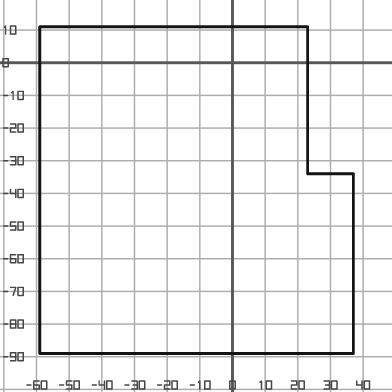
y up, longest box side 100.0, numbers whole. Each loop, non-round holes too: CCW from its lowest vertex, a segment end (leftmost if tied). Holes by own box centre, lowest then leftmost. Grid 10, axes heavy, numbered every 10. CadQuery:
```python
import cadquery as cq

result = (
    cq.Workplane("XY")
    .moveTo(-59.0, -89.0)
    .lineTo(37.0, -89.0)
    .lineTo(37.0, -34.0)
    .lineTo(23.0, -34.0)
    .lineTo(23.0, 11.0)
    .lineTo(-59.0, 11.0)
    .close()
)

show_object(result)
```